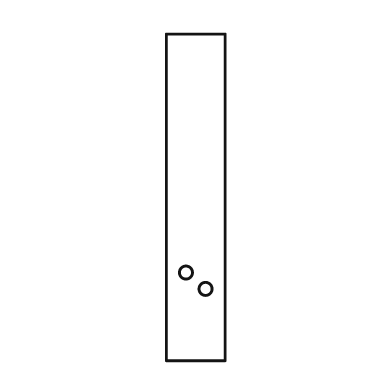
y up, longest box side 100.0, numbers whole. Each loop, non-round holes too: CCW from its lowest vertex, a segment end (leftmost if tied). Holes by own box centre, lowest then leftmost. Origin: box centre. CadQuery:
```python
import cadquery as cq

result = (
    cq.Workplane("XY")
    .moveTo(-9.0, -50.0)
    .lineTo(9.0, -50.0)
    .lineTo(9.0, 50.0)
    .lineTo(-9.0, 50.0)
    .close()
    .moveTo(3.0, -28.0)
    .circle(2.0)
    .moveTo(-3.0, -23.0)
    .circle(2.0)
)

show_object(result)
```